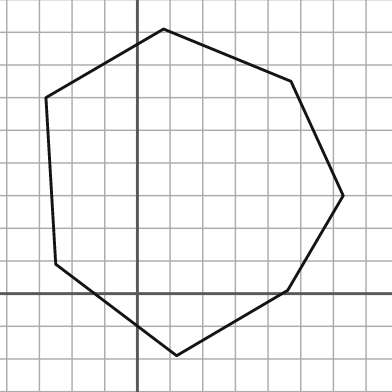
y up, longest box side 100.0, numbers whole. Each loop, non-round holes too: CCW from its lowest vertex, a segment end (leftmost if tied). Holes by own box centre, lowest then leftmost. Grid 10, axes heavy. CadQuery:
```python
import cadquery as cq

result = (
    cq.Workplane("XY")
    .moveTo(12.0, -19.0)
    .lineTo(46.0, 1.0)
    .lineTo(63.0, 30.0)
    .lineTo(47.0, 65.0)
    .lineTo(8.0, 81.0)
    .lineTo(-28.0, 60.0)
    .lineTo(-25.0, 9.0)
    .close()
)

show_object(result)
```